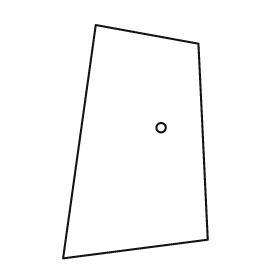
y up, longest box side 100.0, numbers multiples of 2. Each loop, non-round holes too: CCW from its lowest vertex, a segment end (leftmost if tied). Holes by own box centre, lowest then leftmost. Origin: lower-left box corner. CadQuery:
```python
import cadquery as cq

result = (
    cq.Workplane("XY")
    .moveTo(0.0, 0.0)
    .lineTo(62.0, 8.0)
    .lineTo(58.0, 92.0)
    .lineTo(14.0, 100.0)
    .close()
    .moveTo(42.0, 56.0)
    .circle(2.0)
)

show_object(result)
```